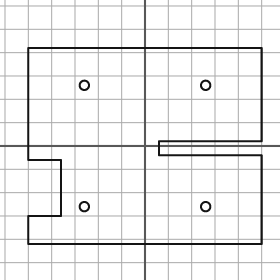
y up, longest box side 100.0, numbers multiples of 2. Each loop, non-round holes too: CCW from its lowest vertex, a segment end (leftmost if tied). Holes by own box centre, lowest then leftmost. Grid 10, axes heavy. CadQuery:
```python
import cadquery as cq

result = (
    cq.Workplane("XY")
    .moveTo(-50.0, -42.0)
    .lineTo(50.0, -42.0)
    .lineTo(50.0, -4.0)
    .lineTo(6.0, -4.0)
    .lineTo(6.0, 2.0)
    .lineTo(50.0, 2.0)
    .lineTo(50.0, 42.0)
    .lineTo(-50.0, 42.0)
    .lineTo(-50.0, -6.0)
    .lineTo(-36.0, -6.0)
    .lineTo(-36.0, -30.0)
    .lineTo(-50.0, -30.0)
    .close()
    .moveTo(-26.0, -26.0)
    .circle(2.0)
    .moveTo(26.0, -26.0)
    .circle(2.0)
    .moveTo(-26.0, 26.0)
    .circle(2.0)
    .moveTo(26.0, 26.0)
    .circle(2.0)
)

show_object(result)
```